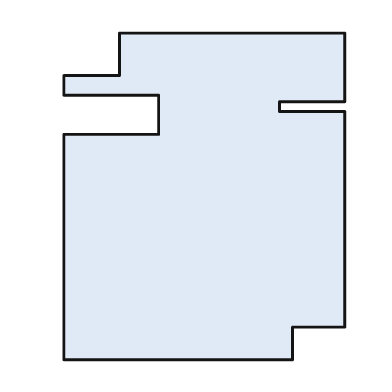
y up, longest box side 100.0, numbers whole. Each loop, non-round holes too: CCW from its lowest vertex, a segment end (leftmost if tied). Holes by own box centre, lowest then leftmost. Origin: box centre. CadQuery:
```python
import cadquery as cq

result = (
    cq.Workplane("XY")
    .moveTo(-43.0, -50.0)
    .lineTo(27.0, -50.0)
    .lineTo(27.0, -40.0)
    .lineTo(43.0, -40.0)
    .lineTo(43.0, 26.0)
    .lineTo(23.0, 26.0)
    .lineTo(23.0, 29.0)
    .lineTo(43.0, 29.0)
    .lineTo(43.0, 50.0)
    .lineTo(-26.0, 50.0)
    .lineTo(-26.0, 37.0)
    .lineTo(-43.0, 37.0)
    .lineTo(-43.0, 31.0)
    .lineTo(-14.0, 31.0)
    .lineTo(-14.0, 19.0)
    .lineTo(-43.0, 19.0)
    .close()
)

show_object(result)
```